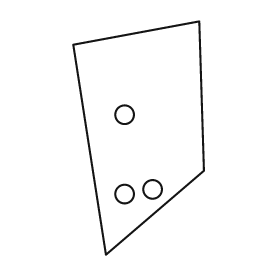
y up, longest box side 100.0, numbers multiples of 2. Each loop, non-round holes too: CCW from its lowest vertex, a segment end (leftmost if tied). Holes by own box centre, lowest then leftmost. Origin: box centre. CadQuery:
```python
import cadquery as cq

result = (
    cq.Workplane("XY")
    .moveTo(-14.0, -50.0)
    .lineTo(28.0, -14.0)
    .lineTo(26.0, 50.0)
    .lineTo(-28.0, 40.0)
    .close()
    .moveTo(-6.0, -24.0)
    .circle(4.0)
    .moveTo(6.0, -22.0)
    .circle(4.0)
    .moveTo(-6.0, 10.0)
    .circle(4.0)
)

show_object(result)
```